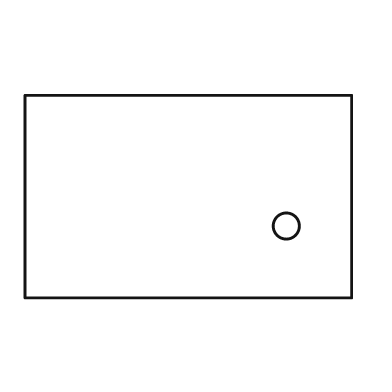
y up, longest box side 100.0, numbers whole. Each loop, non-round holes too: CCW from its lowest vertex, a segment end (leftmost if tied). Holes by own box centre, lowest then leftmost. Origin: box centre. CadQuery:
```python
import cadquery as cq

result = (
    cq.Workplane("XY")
    .moveTo(-50.0, -31.0)
    .lineTo(50.0, -31.0)
    .lineTo(50.0, 31.0)
    .lineTo(-50.0, 31.0)
    .close()
    .moveTo(30.0, -9.0)
    .circle(4.0)
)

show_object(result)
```